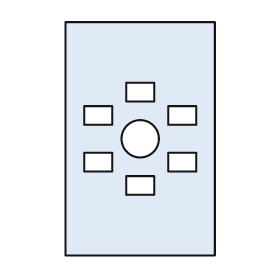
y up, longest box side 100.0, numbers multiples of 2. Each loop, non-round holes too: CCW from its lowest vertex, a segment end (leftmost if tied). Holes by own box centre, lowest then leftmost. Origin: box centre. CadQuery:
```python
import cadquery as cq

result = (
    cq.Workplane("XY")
    .moveTo(-32.0, -50.0)
    .lineTo(32.0, -50.0)
    .lineTo(32.0, 50.0)
    .lineTo(-32.0, 50.0)
    .close()
    .moveTo(-6.0, -24.0)
    .lineTo(6.0, -24.0)
    .lineTo(6.0, -16.0)
    .lineTo(-6.0, -16.0)
    .close()
    .moveTo(-24.0, -14.0)
    .lineTo(-12.0, -14.0)
    .lineTo(-12.0, -6.0)
    .lineTo(-24.0, -6.0)
    .close()
    .moveTo(12.0, -14.0)
    .lineTo(24.0, -14.0)
    .lineTo(24.0, -6.0)
    .lineTo(12.0, -6.0)
    .close()
    .moveTo(0.0, 0.0)
    .circle(8.0)
    .moveTo(-24.0, 6.0)
    .lineTo(-12.0, 6.0)
    .lineTo(-12.0, 14.0)
    .lineTo(-24.0, 14.0)
    .close()
    .moveTo(12.0, 6.0)
    .lineTo(24.0, 6.0)
    .lineTo(24.0, 14.0)
    .lineTo(12.0, 14.0)
    .close()
    .moveTo(-6.0, 16.0)
    .lineTo(6.0, 16.0)
    .lineTo(6.0, 24.0)
    .lineTo(-6.0, 24.0)
    .close()
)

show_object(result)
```